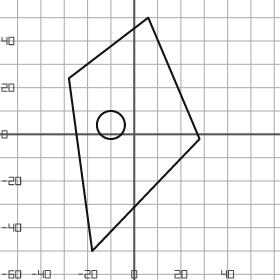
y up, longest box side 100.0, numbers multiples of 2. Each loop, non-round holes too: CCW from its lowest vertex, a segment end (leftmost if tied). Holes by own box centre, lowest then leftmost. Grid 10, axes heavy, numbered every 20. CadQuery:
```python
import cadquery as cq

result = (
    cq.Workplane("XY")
    .moveTo(-18.0, -50.0)
    .lineTo(28.0, -2.0)
    .lineTo(6.0, 50.0)
    .lineTo(-28.0, 24.0)
    .close()
    .moveTo(-10.0, 4.0)
    .circle(6.0)
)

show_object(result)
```